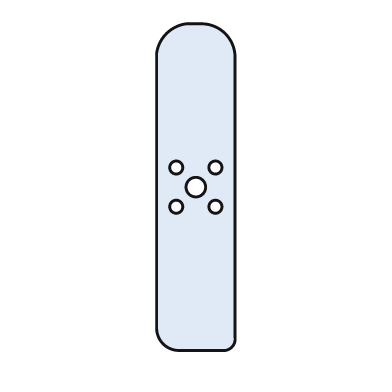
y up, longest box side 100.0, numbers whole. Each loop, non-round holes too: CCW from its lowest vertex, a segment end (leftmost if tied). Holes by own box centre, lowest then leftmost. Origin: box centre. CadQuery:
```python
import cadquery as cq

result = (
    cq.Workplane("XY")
    .moveTo(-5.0, -50.0)
    .lineTo(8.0, -50.0)
    .threePointArc((11.0, -49.0), (12.0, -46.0))
    .lineTo(12.0, 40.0)
    .threePointArc((9.0, 47.0), (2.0, 50.0))
    .lineTo(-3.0, 50.0)
    .threePointArc((-9.0, 47.0), (-12.0, 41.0))
    .lineTo(-12.0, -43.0)
    .threePointArc((-10.0, -48.0), (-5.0, -50.0))
    .close()
    .moveTo(-6.0, -6.0)
    .circle(2.0)
    .moveTo(6.0, -6.0)
    .circle(2.0)
    .moveTo(0.0, 0.0)
    .circle(3.0)
    .moveTo(-6.0, 6.0)
    .circle(2.0)
    .moveTo(6.0, 6.0)
    .circle(2.0)
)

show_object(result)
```